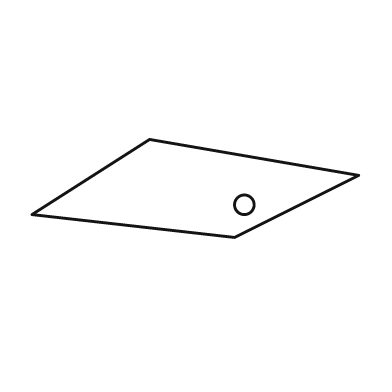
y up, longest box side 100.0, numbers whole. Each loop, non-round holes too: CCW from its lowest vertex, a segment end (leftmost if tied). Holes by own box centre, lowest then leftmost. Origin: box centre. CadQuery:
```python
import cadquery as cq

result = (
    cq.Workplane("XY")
    .moveTo(12.0, -15.0)
    .lineTo(50.0, 4.0)
    .lineTo(-14.0, 15.0)
    .lineTo(-50.0, -8.0)
    .close()
    .moveTo(15.0, -5.0)
    .circle(3.0)
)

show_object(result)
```